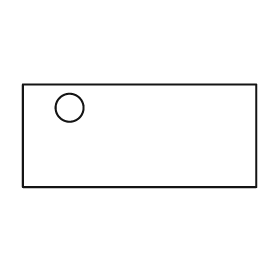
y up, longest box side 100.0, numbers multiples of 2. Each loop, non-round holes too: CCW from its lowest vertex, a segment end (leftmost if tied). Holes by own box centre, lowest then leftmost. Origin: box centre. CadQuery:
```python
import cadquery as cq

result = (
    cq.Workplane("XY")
    .moveTo(-50.0, -22.0)
    .lineTo(50.0, -22.0)
    .lineTo(50.0, 22.0)
    .lineTo(-50.0, 22.0)
    .close()
    .moveTo(-30.0, 12.0)
    .circle(6.0)
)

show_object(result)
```